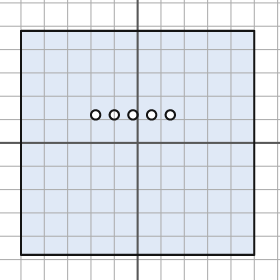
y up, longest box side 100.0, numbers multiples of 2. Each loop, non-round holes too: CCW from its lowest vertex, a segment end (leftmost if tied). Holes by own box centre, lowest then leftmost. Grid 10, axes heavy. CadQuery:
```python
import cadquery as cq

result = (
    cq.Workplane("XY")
    .moveTo(-50.0, -48.0)
    .lineTo(50.0, -48.0)
    .lineTo(50.0, 48.0)
    .lineTo(-50.0, 48.0)
    .close()
    .moveTo(-18.0, 12.0)
    .circle(2.0)
    .moveTo(-10.0, 12.0)
    .circle(2.0)
    .moveTo(-2.0, 12.0)
    .circle(2.0)
    .moveTo(6.0, 12.0)
    .circle(2.0)
    .moveTo(14.0, 12.0)
    .circle(2.0)
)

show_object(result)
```